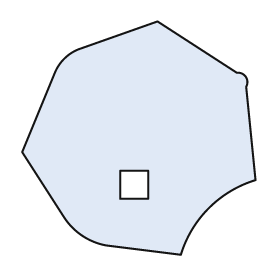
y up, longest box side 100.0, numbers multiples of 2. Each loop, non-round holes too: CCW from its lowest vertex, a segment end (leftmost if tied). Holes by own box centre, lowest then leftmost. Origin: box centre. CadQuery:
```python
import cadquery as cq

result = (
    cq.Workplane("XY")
    .moveTo(18.0, -50.0)
    .threePointArc((30.0, -30.0), (50.0, -18.0))
    .lineTo(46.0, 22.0)
    .threePointArc((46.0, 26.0), (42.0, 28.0))
    .lineTo(8.0, 50.0)
    .lineTo(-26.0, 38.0)
    .threePointArc((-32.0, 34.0), (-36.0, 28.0))
    .lineTo(-50.0, -6.0)
    .lineTo(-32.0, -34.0)
    .threePointArc((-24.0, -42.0), (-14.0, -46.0))
    .close()
    .moveTo(-8.0, -26.0)
    .lineTo(4.0, -26.0)
    .lineTo(4.0, -14.0)
    .lineTo(-8.0, -14.0)
    .close()
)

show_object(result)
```